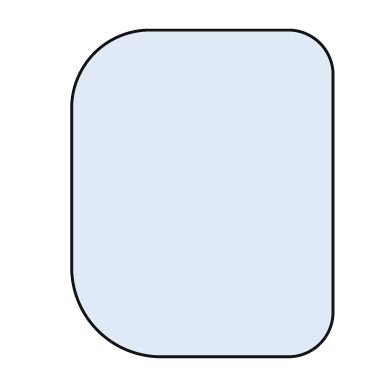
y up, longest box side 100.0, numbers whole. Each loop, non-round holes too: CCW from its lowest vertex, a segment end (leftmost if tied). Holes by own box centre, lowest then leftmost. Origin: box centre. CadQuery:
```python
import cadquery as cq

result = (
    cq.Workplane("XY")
    .moveTo(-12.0, -50.0)
    .lineTo(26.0, -50.0)
    .threePointArc((36.0, -46.0), (40.0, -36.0))
    .lineTo(40.0, 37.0)
    .threePointArc((36.0, 46.0), (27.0, 50.0))
    .lineTo(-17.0, 50.0)
    .threePointArc((-33.0, 43.0), (-40.0, 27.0))
    .lineTo(-40.0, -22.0)
    .threePointArc((-32.0, -42.0), (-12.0, -50.0))
    .close()
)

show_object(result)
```